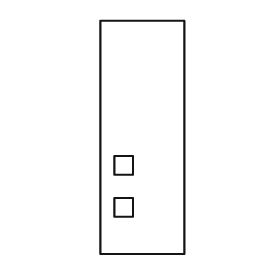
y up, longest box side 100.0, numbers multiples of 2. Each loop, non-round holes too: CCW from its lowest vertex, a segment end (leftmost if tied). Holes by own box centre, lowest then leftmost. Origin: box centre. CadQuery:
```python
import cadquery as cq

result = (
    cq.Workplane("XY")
    .moveTo(-18.0, -50.0)
    .lineTo(18.0, -50.0)
    .lineTo(18.0, 50.0)
    .lineTo(-18.0, 50.0)
    .close()
    .moveTo(-12.0, -34.0)
    .lineTo(-4.0, -34.0)
    .lineTo(-4.0, -26.0)
    .lineTo(-12.0, -26.0)
    .close()
    .moveTo(-12.0, -16.0)
    .lineTo(-4.0, -16.0)
    .lineTo(-4.0, -8.0)
    .lineTo(-12.0, -8.0)
    .close()
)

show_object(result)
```